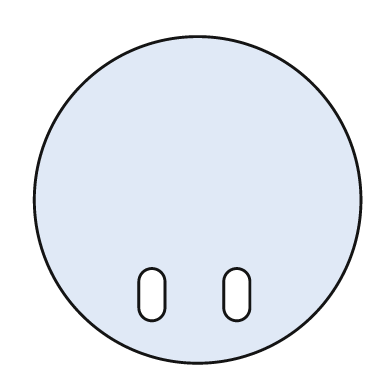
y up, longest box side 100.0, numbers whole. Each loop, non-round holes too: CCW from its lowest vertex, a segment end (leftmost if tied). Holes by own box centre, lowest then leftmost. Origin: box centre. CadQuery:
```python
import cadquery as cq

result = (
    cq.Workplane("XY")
    .moveTo(0.0, 0.0)
    .circle(50.0)
    .moveTo(-18.0, -33.0)
    .threePointArc((-14.0, -37.0), (-10.0, -33.0))
    .lineTo(-10.0, -25.0)
    .threePointArc((-14.0, -21.0), (-18.0, -25.0))
    .close()
    .moveTo(8.0, -33.0)
    .threePointArc((12.0, -37.0), (16.0, -33.0))
    .lineTo(16.0, -25.0)
    .threePointArc((12.0, -21.0), (8.0, -25.0))
    .close()
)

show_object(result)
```